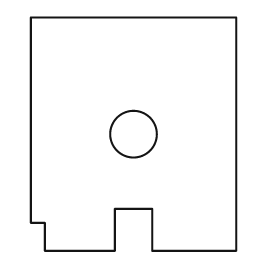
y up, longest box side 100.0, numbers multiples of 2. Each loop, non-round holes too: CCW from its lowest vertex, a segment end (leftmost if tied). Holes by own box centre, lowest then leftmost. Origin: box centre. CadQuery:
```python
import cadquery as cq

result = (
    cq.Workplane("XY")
    .moveTo(-38.0, -50.0)
    .lineTo(-8.0, -50.0)
    .lineTo(-8.0, -32.0)
    .lineTo(8.0, -32.0)
    .lineTo(8.0, -50.0)
    .lineTo(44.0, -50.0)
    .lineTo(44.0, 50.0)
    .lineTo(-44.0, 50.0)
    .lineTo(-44.0, -38.0)
    .lineTo(-38.0, -38.0)
    .close()
    .moveTo(0.0, 0.0)
    .circle(10.0)
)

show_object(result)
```